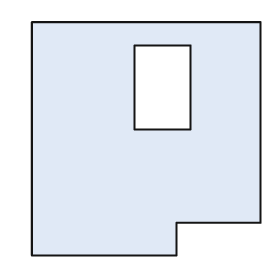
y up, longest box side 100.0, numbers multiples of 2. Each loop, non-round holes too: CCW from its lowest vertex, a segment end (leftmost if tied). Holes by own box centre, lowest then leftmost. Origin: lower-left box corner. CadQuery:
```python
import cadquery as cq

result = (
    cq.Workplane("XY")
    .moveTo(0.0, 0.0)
    .lineTo(62.0, 0.0)
    .lineTo(62.0, 14.0)
    .lineTo(98.0, 14.0)
    .lineTo(98.0, 100.0)
    .lineTo(0.0, 100.0)
    .close()
    .moveTo(44.0, 54.0)
    .lineTo(68.0, 54.0)
    .lineTo(68.0, 90.0)
    .lineTo(44.0, 90.0)
    .close()
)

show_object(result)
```